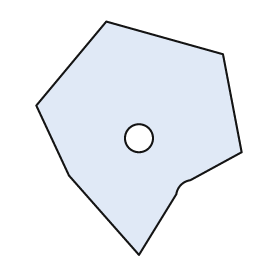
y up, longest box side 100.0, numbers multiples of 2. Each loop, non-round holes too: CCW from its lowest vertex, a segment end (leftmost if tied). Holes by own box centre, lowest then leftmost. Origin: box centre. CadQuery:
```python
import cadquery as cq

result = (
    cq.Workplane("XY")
    .moveTo(0.0, -50.0)
    .lineTo(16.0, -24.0)
    .threePointArc((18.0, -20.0), (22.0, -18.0))
    .lineTo(44.0, -6.0)
    .lineTo(36.0, 36.0)
    .lineTo(-14.0, 50.0)
    .lineTo(-44.0, 14.0)
    .lineTo(-30.0, -16.0)
    .close()
    .moveTo(0.0, 0.0)
    .circle(6.0)
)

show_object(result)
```